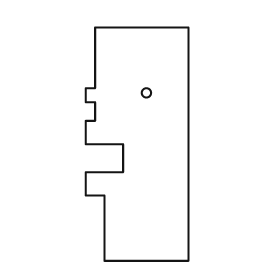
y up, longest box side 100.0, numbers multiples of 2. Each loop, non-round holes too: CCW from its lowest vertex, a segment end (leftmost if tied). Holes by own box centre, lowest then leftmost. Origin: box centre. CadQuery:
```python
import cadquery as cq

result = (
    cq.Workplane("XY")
    .moveTo(-14.0, -50.0)
    .lineTo(22.0, -50.0)
    .lineTo(22.0, 50.0)
    .lineTo(-18.0, 50.0)
    .lineTo(-18.0, 24.0)
    .lineTo(-22.0, 24.0)
    .lineTo(-22.0, 18.0)
    .lineTo(-18.0, 18.0)
    .lineTo(-18.0, 10.0)
    .lineTo(-22.0, 10.0)
    .lineTo(-22.0, 0.0)
    .lineTo(-6.0, 0.0)
    .lineTo(-6.0, -12.0)
    .lineTo(-22.0, -12.0)
    .lineTo(-22.0, -22.0)
    .lineTo(-14.0, -22.0)
    .close()
    .moveTo(4.0, 22.0)
    .circle(2.0)
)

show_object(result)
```